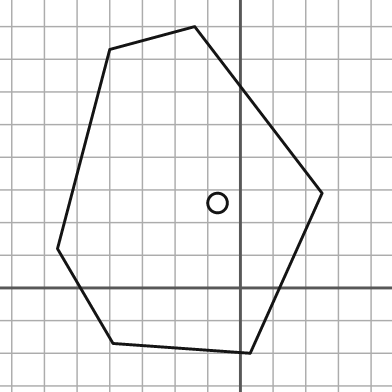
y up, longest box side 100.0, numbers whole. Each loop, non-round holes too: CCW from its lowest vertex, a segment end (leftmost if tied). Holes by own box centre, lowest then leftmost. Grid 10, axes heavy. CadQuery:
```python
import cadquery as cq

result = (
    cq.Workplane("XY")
    .moveTo(3.0, -20.0)
    .lineTo(25.0, 29.0)
    .lineTo(-14.0, 80.0)
    .lineTo(-40.0, 73.0)
    .lineTo(-56.0, 12.0)
    .lineTo(-39.0, -17.0)
    .close()
    .moveTo(-7.0, 26.0)
    .circle(3.0)
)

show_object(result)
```